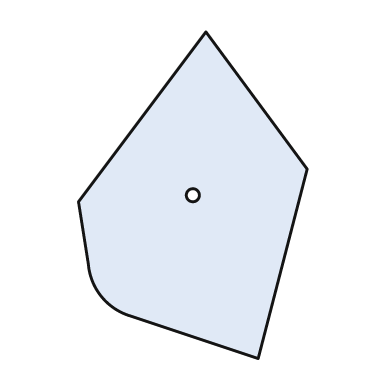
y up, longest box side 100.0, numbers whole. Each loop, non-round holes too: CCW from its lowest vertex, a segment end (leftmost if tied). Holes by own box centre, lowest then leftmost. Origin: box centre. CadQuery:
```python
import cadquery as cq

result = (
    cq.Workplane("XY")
    .moveTo(20.0, -50.0)
    .lineTo(35.0, 8.0)
    .lineTo(4.0, 50.0)
    .lineTo(-35.0, -2.0)
    .lineTo(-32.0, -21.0)
    .threePointArc((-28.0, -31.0), (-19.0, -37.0))
    .close()
    .moveTo(0.0, 0.0)
    .circle(2.0)
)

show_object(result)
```